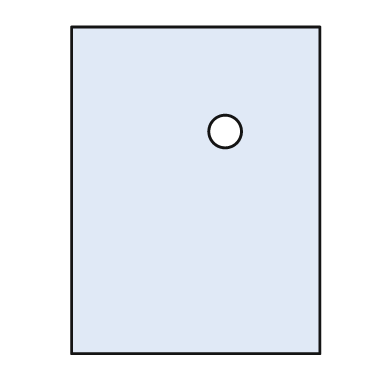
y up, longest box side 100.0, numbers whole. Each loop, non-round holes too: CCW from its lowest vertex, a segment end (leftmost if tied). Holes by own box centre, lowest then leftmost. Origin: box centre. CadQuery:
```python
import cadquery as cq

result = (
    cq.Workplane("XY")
    .moveTo(-38.0, -50.0)
    .lineTo(38.0, -50.0)
    .lineTo(38.0, 50.0)
    .lineTo(-38.0, 50.0)
    .close()
    .moveTo(9.0, 18.0)
    .circle(5.0)
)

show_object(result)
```